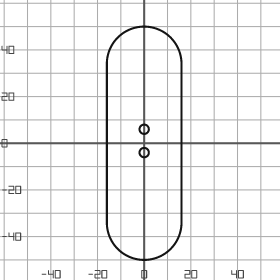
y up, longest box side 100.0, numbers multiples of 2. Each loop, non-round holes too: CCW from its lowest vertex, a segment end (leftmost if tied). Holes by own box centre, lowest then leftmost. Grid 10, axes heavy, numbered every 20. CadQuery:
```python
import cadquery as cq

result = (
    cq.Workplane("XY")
    .moveTo(-16.0, -34.0)
    .threePointArc((0.0, -50.0), (16.0, -34.0))
    .lineTo(16.0, 34.0)
    .threePointArc((0.0, 50.0), (-16.0, 34.0))
    .close()
    .moveTo(0.0, -4.0)
    .circle(2.0)
    .moveTo(0.0, 6.0)
    .circle(2.0)
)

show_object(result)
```